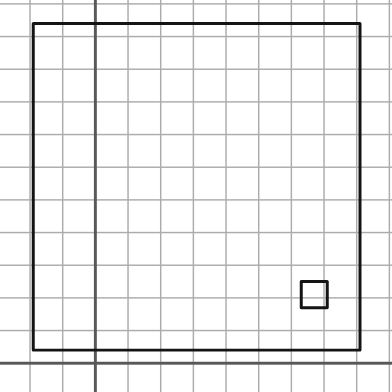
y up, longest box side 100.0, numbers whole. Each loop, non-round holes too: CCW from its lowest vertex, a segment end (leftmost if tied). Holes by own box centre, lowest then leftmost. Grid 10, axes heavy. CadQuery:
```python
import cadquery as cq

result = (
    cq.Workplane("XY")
    .moveTo(-19.0, 4.0)
    .lineTo(81.0, 4.0)
    .lineTo(81.0, 104.0)
    .lineTo(-19.0, 104.0)
    .close()
    .moveTo(63.0, 17.0)
    .lineTo(71.0, 17.0)
    .lineTo(71.0, 25.0)
    .lineTo(63.0, 25.0)
    .close()
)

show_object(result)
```